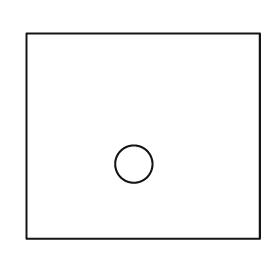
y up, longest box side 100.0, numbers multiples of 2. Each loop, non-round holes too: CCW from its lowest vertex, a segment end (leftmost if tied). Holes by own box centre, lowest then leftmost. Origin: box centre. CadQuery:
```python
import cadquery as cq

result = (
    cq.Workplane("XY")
    .moveTo(-50.0, -44.0)
    .lineTo(50.0, -44.0)
    .lineTo(50.0, 44.0)
    .lineTo(-50.0, 44.0)
    .close()
    .moveTo(-4.0, -12.0)
    .circle(8.0)
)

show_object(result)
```